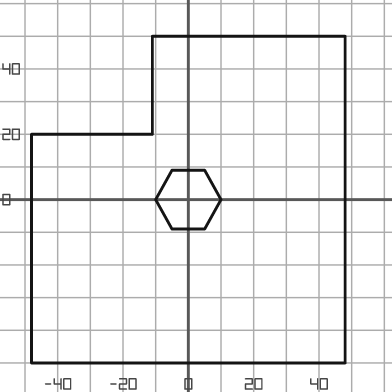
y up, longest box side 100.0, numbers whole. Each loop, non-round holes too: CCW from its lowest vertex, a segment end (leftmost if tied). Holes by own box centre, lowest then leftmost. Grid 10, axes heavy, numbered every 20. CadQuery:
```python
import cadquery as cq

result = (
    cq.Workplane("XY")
    .moveTo(-48.0, -50.0)
    .lineTo(48.0, -50.0)
    .lineTo(48.0, 50.0)
    .lineTo(-11.0, 50.0)
    .lineTo(-11.0, 20.0)
    .lineTo(-48.0, 20.0)
    .close()
    .moveTo(-5.0, -9.0)
    .lineTo(5.0, -9.0)
    .lineTo(10.0, 0.0)
    .lineTo(5.0, 9.0)
    .lineTo(-5.0, 9.0)
    .lineTo(-10.0, 0.0)
    .close()
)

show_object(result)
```